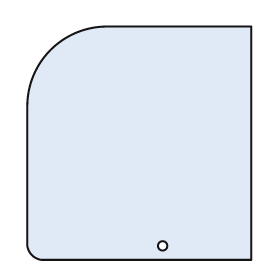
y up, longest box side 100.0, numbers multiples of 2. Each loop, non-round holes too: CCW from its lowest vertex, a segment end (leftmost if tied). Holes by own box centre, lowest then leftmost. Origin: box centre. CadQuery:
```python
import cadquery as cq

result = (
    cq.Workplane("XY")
    .moveTo(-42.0, -50.0)
    .lineTo(48.0, -50.0)
    .lineTo(48.0, 50.0)
    .lineTo(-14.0, 50.0)
    .threePointArc((-38.0, 40.0), (-48.0, 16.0))
    .lineTo(-48.0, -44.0)
    .threePointArc((-46.0, -48.0), (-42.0, -50.0))
    .close()
    .moveTo(10.0, -44.0)
    .circle(2.0)
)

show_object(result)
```